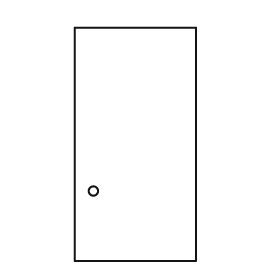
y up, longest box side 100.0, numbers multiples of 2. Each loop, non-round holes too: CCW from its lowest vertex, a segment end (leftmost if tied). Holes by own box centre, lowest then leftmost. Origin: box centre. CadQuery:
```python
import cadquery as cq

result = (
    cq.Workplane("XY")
    .moveTo(-26.0, -50.0)
    .lineTo(26.0, -50.0)
    .lineTo(26.0, 50.0)
    .lineTo(-26.0, 50.0)
    .close()
    .moveTo(-18.0, -20.0)
    .circle(2.0)
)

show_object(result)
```